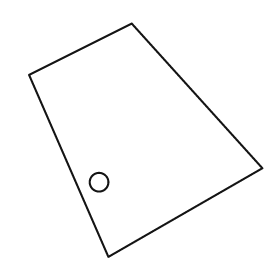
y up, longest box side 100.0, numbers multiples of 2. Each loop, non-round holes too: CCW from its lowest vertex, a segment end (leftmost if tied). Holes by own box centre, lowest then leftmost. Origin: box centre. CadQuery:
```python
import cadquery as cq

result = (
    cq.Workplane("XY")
    .moveTo(-16.0, -50.0)
    .lineTo(50.0, -12.0)
    .lineTo(-6.0, 50.0)
    .lineTo(-50.0, 28.0)
    .close()
    .moveTo(-20.0, -18.0)
    .circle(4.0)
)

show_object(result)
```